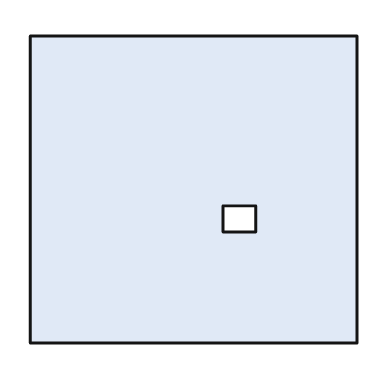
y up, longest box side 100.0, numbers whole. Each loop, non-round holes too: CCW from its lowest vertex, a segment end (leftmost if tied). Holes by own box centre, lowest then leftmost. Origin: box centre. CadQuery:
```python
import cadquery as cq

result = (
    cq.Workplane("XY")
    .moveTo(-50.0, -47.0)
    .lineTo(50.0, -47.0)
    .lineTo(50.0, 47.0)
    .lineTo(-50.0, 47.0)
    .close()
    .moveTo(9.0, -13.0)
    .lineTo(19.0, -13.0)
    .lineTo(19.0, -5.0)
    .lineTo(9.0, -5.0)
    .close()
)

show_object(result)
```